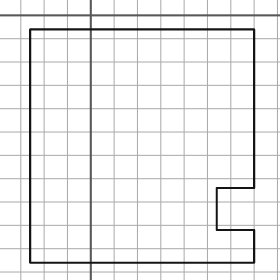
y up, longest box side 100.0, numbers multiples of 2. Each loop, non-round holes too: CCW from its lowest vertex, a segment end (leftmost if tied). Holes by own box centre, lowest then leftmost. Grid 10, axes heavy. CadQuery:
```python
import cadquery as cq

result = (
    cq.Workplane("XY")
    .moveTo(-26.0, -106.0)
    .lineTo(70.0, -106.0)
    .lineTo(70.0, -92.0)
    .lineTo(54.0, -92.0)
    .lineTo(54.0, -74.0)
    .lineTo(70.0, -74.0)
    .lineTo(70.0, -6.0)
    .lineTo(-26.0, -6.0)
    .close()
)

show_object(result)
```